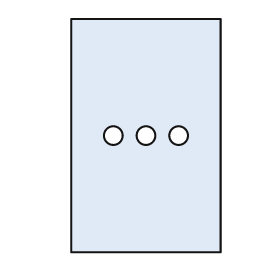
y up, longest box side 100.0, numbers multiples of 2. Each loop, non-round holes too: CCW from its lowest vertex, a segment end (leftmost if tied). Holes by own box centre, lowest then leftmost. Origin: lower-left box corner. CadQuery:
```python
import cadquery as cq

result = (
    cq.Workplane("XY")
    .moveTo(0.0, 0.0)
    .lineTo(64.0, 0.0)
    .lineTo(64.0, 100.0)
    .lineTo(0.0, 100.0)
    .close()
    .moveTo(18.0, 50.0)
    .circle(4.0)
    .moveTo(32.0, 50.0)
    .circle(4.0)
    .moveTo(46.0, 50.0)
    .circle(4.0)
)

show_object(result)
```